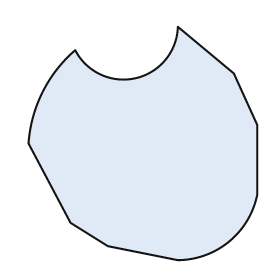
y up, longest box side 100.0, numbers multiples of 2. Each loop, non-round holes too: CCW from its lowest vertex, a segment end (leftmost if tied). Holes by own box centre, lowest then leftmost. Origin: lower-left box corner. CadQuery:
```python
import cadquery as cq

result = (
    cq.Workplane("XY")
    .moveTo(64.0, 0.0)
    .threePointArc((86.0, 8.0), (98.0, 28.0))
    .lineTo(98.0, 58.0)
    .lineTo(88.0, 80.0)
    .lineTo(64.0, 100.0)
    .threePointArc((46.0, 78.0), (20.0, 90.0))
    .threePointArc((6.0, 72.0), (0.0, 50.0))
    .lineTo(18.0, 16.0)
    .lineTo(34.0, 6.0)
    .close()
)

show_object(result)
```